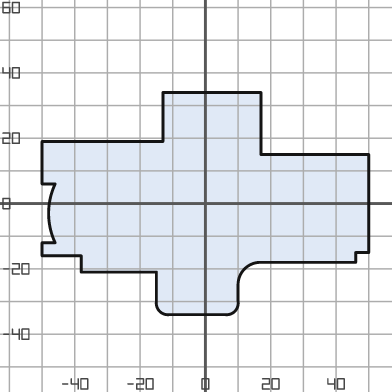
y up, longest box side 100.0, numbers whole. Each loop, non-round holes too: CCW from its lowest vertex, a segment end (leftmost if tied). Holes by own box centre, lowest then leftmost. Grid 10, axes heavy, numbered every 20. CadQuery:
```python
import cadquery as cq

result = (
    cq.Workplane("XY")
    .moveTo(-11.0, -34.0)
    .lineTo(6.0, -34.0)
    .threePointArc((9.0, -33.0), (10.0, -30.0))
    .lineTo(10.0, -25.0)
    .threePointArc((12.0, -20.0), (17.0, -18.0))
    .lineTo(46.0, -18.0)
    .lineTo(46.0, -15.0)
    .lineTo(50.0, -15.0)
    .lineTo(50.0, 15.0)
    .lineTo(17.0, 15.0)
    .lineTo(17.0, 34.0)
    .lineTo(-13.0, 34.0)
    .lineTo(-13.0, 19.0)
    .lineTo(-50.0, 19.0)
    .lineTo(-50.0, 6.0)
    .lineTo(-46.0, 6.0)
    .threePointArc((-48.0, -3.0), (-46.0, -12.0))
    .lineTo(-50.0, -12.0)
    .lineTo(-50.0, -16.0)
    .lineTo(-38.0, -16.0)
    .lineTo(-38.0, -21.0)
    .lineTo(-15.0, -21.0)
    .lineTo(-15.0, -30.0)
    .threePointArc((-14.0, -33.0), (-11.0, -34.0))
    .close()
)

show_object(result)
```